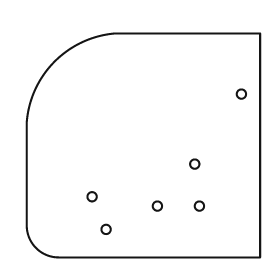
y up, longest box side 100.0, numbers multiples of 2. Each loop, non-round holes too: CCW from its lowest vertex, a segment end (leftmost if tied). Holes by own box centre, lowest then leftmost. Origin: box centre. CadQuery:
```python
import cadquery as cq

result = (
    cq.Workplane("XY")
    .moveTo(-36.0, -48.0)
    .lineTo(50.0, -48.0)
    .lineTo(50.0, 48.0)
    .lineTo(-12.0, 48.0)
    .threePointArc((-38.0, 36.0), (-50.0, 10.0))
    .lineTo(-50.0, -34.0)
    .threePointArc((-46.0, -44.0), (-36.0, -48.0))
    .close()
    .moveTo(-16.0, -36.0)
    .circle(2.0)
    .moveTo(6.0, -26.0)
    .circle(2.0)
    .moveTo(24.0, -26.0)
    .circle(2.0)
    .moveTo(-22.0, -22.0)
    .circle(2.0)
    .moveTo(22.0, -8.0)
    .circle(2.0)
    .moveTo(42.0, 22.0)
    .circle(2.0)
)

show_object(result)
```